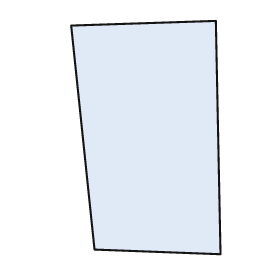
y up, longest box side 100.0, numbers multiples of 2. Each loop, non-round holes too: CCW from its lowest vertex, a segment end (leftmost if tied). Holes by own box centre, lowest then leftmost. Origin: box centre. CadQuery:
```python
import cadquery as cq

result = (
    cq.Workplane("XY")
    .moveTo(32.0, -50.0)
    .lineTo(30.0, 50.0)
    .lineTo(-32.0, 48.0)
    .lineTo(-22.0, -48.0)
    .close()
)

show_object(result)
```